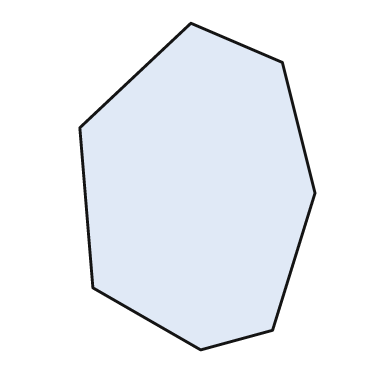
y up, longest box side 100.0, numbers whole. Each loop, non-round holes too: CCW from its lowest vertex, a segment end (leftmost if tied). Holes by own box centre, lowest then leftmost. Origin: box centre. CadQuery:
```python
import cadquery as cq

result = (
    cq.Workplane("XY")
    .moveTo(1.0, -50.0)
    .lineTo(23.0, -44.0)
    .lineTo(36.0, -2.0)
    .lineTo(26.0, 38.0)
    .lineTo(-2.0, 50.0)
    .lineTo(-36.0, 18.0)
    .lineTo(-32.0, -31.0)
    .close()
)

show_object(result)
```